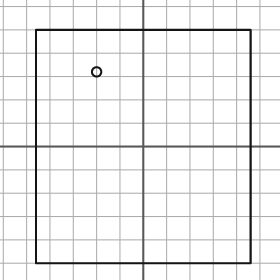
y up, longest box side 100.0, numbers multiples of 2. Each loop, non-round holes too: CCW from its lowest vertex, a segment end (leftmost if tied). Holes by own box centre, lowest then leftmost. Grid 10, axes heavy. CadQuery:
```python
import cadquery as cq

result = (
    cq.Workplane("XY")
    .moveTo(-46.0, -50.0)
    .lineTo(46.0, -50.0)
    .lineTo(46.0, 50.0)
    .lineTo(-46.0, 50.0)
    .close()
    .moveTo(-20.0, 32.0)
    .circle(2.0)
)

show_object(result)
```